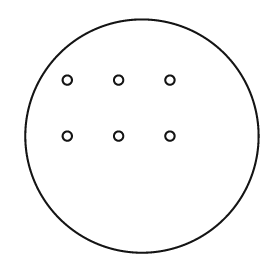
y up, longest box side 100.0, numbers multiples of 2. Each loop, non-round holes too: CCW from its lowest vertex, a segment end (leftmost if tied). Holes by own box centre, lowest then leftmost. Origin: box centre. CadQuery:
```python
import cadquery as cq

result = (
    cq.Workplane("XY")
    .moveTo(0.0, 0.0)
    .circle(50.0)
    .moveTo(-32.0, 0.0)
    .circle(2.0)
    .moveTo(-10.0, 0.0)
    .circle(2.0)
    .moveTo(12.0, 0.0)
    .circle(2.0)
    .moveTo(-32.0, 24.0)
    .circle(2.0)
    .moveTo(-10.0, 24.0)
    .circle(2.0)
    .moveTo(12.0, 24.0)
    .circle(2.0)
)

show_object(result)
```